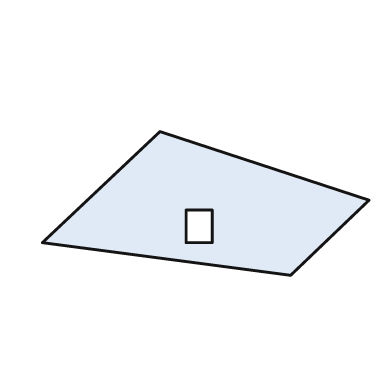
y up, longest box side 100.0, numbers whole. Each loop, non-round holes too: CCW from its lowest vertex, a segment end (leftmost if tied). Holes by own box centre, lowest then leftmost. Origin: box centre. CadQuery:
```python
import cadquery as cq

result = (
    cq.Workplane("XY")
    .moveTo(26.0, -22.0)
    .lineTo(50.0, 1.0)
    .lineTo(-14.0, 22.0)
    .lineTo(-50.0, -12.0)
    .close()
    .moveTo(-6.0, -12.0)
    .lineTo(2.0, -12.0)
    .lineTo(2.0, -2.0)
    .lineTo(-6.0, -2.0)
    .close()
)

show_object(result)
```